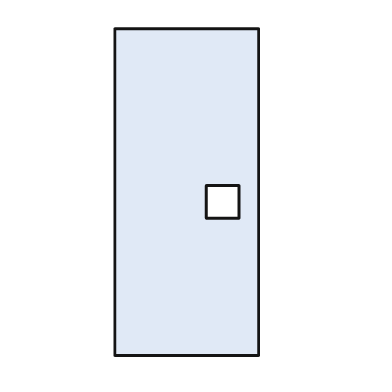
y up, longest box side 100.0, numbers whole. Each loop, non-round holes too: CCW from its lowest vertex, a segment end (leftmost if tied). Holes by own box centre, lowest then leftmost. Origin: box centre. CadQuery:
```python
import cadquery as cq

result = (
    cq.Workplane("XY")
    .moveTo(-22.0, -50.0)
    .lineTo(22.0, -50.0)
    .lineTo(22.0, 50.0)
    .lineTo(-22.0, 50.0)
    .close()
    .moveTo(6.0, -8.0)
    .lineTo(16.0, -8.0)
    .lineTo(16.0, 2.0)
    .lineTo(6.0, 2.0)
    .close()
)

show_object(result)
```